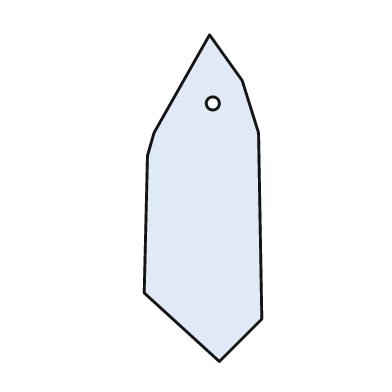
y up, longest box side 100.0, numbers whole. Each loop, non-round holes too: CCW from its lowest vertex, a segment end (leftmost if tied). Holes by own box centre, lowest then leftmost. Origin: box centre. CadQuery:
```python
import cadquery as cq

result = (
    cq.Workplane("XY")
    .moveTo(5.0, -50.0)
    .lineTo(18.0, -37.0)
    .lineTo(17.0, 20.0)
    .lineTo(12.0, 36.0)
    .lineTo(2.0, 50.0)
    .lineTo(-15.0, 20.0)
    .lineTo(-17.0, 13.0)
    .lineTo(-18.0, -29.0)
    .close()
    .moveTo(3.0, 29.0)
    .circle(2.0)
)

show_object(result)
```